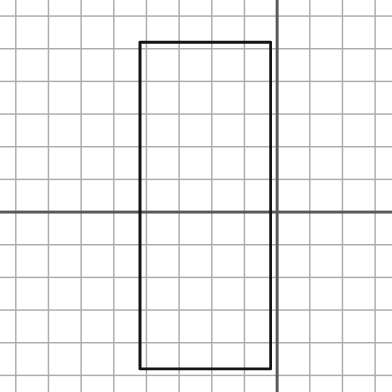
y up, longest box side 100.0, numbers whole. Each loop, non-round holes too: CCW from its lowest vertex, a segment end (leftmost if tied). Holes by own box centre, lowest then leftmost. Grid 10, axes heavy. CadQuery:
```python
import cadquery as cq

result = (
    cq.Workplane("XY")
    .moveTo(-42.0, -48.0)
    .lineTo(-2.0, -48.0)
    .lineTo(-2.0, 52.0)
    .lineTo(-42.0, 52.0)
    .close()
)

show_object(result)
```